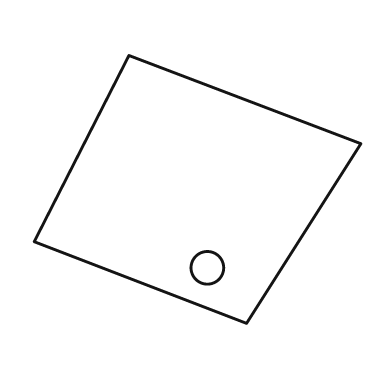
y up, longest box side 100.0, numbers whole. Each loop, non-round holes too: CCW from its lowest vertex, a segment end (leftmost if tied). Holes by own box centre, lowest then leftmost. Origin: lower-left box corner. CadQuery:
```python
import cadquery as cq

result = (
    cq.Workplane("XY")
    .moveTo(65.0, 0.0)
    .lineTo(100.0, 55.0)
    .lineTo(29.0, 82.0)
    .lineTo(0.0, 25.0)
    .close()
    .moveTo(53.0, 17.0)
    .circle(5.0)
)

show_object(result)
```